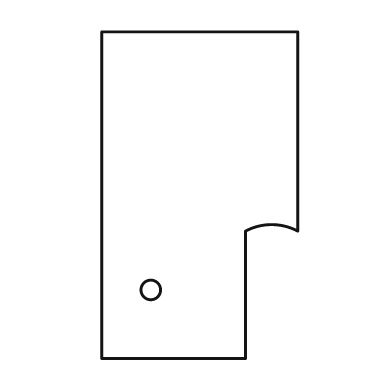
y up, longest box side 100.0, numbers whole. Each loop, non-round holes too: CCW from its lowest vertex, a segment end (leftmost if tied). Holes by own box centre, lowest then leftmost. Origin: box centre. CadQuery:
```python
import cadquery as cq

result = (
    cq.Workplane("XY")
    .moveTo(-30.0, -50.0)
    .lineTo(14.0, -50.0)
    .lineTo(14.0, -11.0)
    .threePointArc((22.0, -9.0), (30.0, -11.0))
    .lineTo(30.0, 50.0)
    .lineTo(-30.0, 50.0)
    .close()
    .moveTo(-15.0, -29.0)
    .circle(3.0)
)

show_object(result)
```